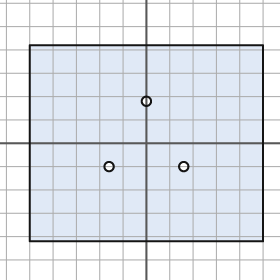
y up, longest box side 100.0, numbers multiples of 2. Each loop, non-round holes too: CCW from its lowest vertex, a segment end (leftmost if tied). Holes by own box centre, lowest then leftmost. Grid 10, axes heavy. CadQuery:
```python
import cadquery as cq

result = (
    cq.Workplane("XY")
    .moveTo(-50.0, -42.0)
    .lineTo(50.0, -42.0)
    .lineTo(50.0, 42.0)
    .lineTo(-50.0, 42.0)
    .close()
    .moveTo(-16.0, -10.0)
    .circle(2.0)
    .moveTo(16.0, -10.0)
    .circle(2.0)
    .moveTo(0.0, 18.0)
    .circle(2.0)
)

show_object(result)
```